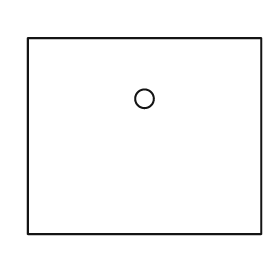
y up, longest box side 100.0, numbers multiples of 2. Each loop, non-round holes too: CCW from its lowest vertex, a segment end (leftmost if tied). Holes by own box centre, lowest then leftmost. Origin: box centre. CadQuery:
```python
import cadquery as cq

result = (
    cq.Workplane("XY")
    .moveTo(-50.0, -42.0)
    .lineTo(50.0, -42.0)
    .lineTo(50.0, 42.0)
    .lineTo(-50.0, 42.0)
    .close()
    .moveTo(0.0, 16.0)
    .circle(4.0)
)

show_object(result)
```